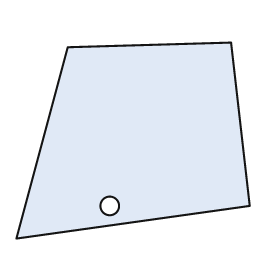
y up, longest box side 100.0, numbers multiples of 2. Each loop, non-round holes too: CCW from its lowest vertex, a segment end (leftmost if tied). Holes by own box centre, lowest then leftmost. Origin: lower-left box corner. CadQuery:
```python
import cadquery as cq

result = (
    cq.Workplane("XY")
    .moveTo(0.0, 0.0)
    .lineTo(100.0, 14.0)
    .lineTo(92.0, 84.0)
    .lineTo(22.0, 82.0)
    .close()
    .moveTo(40.0, 14.0)
    .circle(4.0)
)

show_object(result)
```